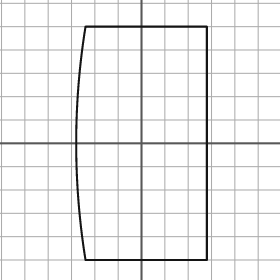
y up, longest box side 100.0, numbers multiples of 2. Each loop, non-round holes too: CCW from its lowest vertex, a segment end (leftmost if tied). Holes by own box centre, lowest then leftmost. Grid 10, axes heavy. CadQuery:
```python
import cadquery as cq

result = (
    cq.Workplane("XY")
    .moveTo(-24.0, -50.0)
    .lineTo(28.0, -50.0)
    .lineTo(28.0, 50.0)
    .lineTo(-24.0, 50.0)
    .threePointArc((-28.0, 0.0), (-24.0, -50.0))
    .close()
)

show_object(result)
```